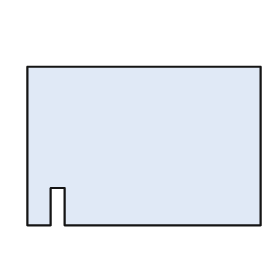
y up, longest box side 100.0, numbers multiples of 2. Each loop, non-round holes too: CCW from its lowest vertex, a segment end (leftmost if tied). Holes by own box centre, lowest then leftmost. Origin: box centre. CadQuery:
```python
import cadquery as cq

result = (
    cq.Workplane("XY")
    .moveTo(-50.0, -34.0)
    .lineTo(-40.0, -34.0)
    .lineTo(-40.0, -18.0)
    .lineTo(-34.0, -18.0)
    .lineTo(-34.0, -34.0)
    .lineTo(50.0, -34.0)
    .lineTo(50.0, 34.0)
    .lineTo(-50.0, 34.0)
    .close()
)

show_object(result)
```